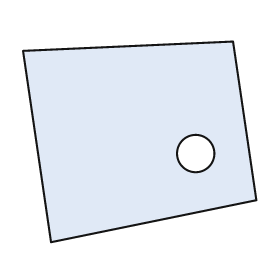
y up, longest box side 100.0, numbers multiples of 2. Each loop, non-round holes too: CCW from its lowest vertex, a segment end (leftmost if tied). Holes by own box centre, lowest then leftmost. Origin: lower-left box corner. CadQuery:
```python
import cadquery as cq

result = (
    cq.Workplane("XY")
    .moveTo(12.0, 0.0)
    .lineTo(100.0, 18.0)
    .lineTo(90.0, 86.0)
    .lineTo(0.0, 82.0)
    .close()
    .moveTo(74.0, 38.0)
    .circle(8.0)
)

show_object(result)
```